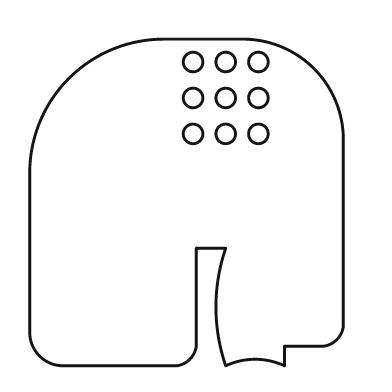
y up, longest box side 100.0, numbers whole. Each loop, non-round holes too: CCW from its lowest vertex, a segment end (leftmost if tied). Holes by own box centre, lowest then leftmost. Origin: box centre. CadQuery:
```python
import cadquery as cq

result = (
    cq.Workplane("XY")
    .moveTo(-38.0, -50.0)
    .lineTo(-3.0, -50.0)
    .threePointArc((1.0, -48.0), (3.0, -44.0))
    .lineTo(3.0, -14.0)
    .lineTo(12.0, -14.0)
    .threePointArc((9.0, -32.0), (12.0, -50.0))
    .threePointArc((21.0, -48.0), (30.0, -50.0))
    .lineTo(30.0, -44.0)
    .lineTo(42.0, -44.0)
    .threePointArc((46.0, -42.0), (48.0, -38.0))
    .lineTo(48.0, 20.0)
    .threePointArc((39.0, 41.0), (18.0, 50.0))
    .lineTo(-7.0, 50.0)
    .threePointArc((-36.0, 38.0), (-48.0, 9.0))
    .lineTo(-48.0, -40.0)
    .threePointArc((-45.0, -47.0), (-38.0, -50.0))
    .close()
    .moveTo(2.0, 21.0)
    .circle(3.0)
    .moveTo(12.0, 21.0)
    .circle(3.0)
    .moveTo(22.0, 21.0)
    .circle(3.0)
    .moveTo(2.0, 32.0)
    .circle(3.0)
    .moveTo(12.0, 32.0)
    .circle(3.0)
    .moveTo(22.0, 32.0)
    .circle(3.0)
    .moveTo(2.0, 43.0)
    .circle(3.0)
    .moveTo(12.0, 43.0)
    .circle(3.0)
    .moveTo(22.0, 43.0)
    .circle(3.0)
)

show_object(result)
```